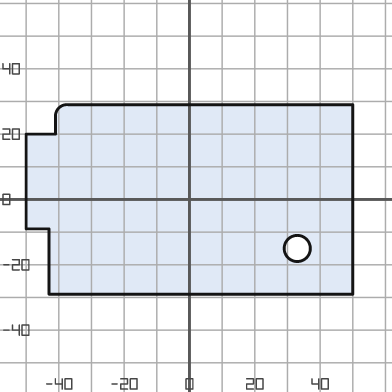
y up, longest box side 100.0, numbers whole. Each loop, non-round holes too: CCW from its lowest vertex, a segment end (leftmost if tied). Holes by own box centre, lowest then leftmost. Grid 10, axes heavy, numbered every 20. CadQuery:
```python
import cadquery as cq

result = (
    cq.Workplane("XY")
    .moveTo(-43.0, -29.0)
    .lineTo(50.0, -29.0)
    .lineTo(50.0, 29.0)
    .lineTo(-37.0, 29.0)
    .threePointArc((-40.0, 28.0), (-41.0, 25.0))
    .lineTo(-41.0, 20.0)
    .lineTo(-50.0, 20.0)
    .lineTo(-50.0, -9.0)
    .lineTo(-43.0, -9.0)
    .close()
    .moveTo(33.0, -15.0)
    .circle(4.0)
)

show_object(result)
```